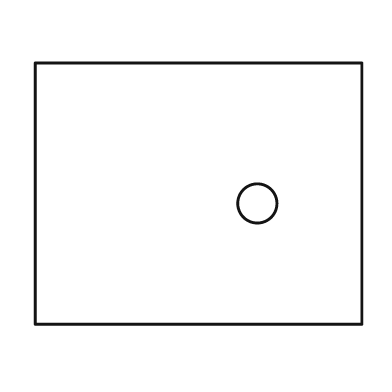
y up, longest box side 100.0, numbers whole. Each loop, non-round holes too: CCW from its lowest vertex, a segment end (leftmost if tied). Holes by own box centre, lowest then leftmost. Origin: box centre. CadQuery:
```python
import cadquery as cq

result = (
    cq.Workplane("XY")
    .moveTo(-50.0, -40.0)
    .lineTo(50.0, -40.0)
    .lineTo(50.0, 40.0)
    .lineTo(-50.0, 40.0)
    .close()
    .moveTo(18.0, -3.0)
    .circle(6.0)
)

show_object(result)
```